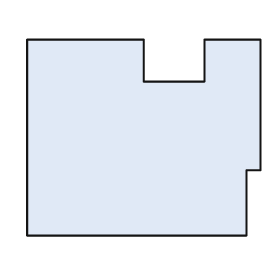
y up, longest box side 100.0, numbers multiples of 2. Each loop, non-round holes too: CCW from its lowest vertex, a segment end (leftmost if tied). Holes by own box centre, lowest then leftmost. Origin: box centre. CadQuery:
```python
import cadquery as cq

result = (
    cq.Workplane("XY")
    .moveTo(-50.0, -42.0)
    .lineTo(44.0, -42.0)
    .lineTo(44.0, -14.0)
    .lineTo(50.0, -14.0)
    .lineTo(50.0, 42.0)
    .lineTo(26.0, 42.0)
    .lineTo(26.0, 24.0)
    .lineTo(0.0, 24.0)
    .lineTo(0.0, 42.0)
    .lineTo(-50.0, 42.0)
    .close()
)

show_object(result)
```